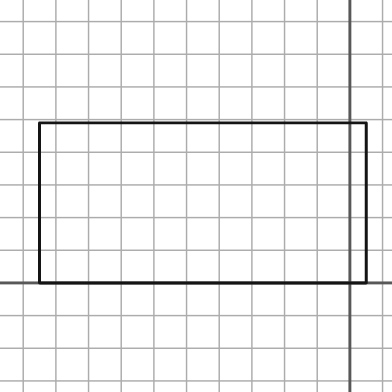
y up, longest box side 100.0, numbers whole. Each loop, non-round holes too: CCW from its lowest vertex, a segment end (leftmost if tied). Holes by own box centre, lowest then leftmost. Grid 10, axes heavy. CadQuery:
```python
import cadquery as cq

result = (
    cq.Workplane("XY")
    .moveTo(-95.0, 0.0)
    .lineTo(5.0, 0.0)
    .lineTo(5.0, 49.0)
    .lineTo(-95.0, 49.0)
    .close()
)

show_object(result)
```